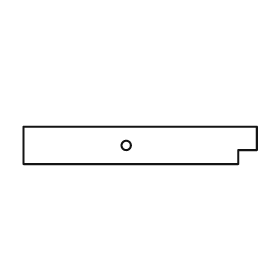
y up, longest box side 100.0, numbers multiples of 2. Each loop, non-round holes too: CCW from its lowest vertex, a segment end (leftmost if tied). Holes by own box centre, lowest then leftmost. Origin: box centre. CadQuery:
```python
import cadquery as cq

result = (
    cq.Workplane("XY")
    .moveTo(-50.0, -8.0)
    .lineTo(42.0, -8.0)
    .lineTo(42.0, -2.0)
    .lineTo(50.0, -2.0)
    .lineTo(50.0, 8.0)
    .lineTo(-50.0, 8.0)
    .close()
    .moveTo(-6.0, 0.0)
    .circle(2.0)
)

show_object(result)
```